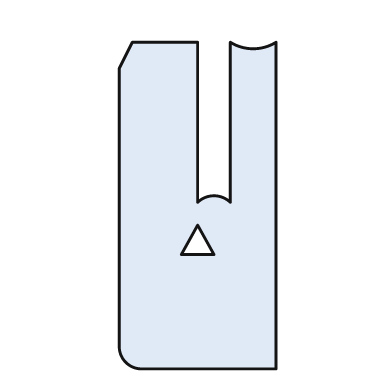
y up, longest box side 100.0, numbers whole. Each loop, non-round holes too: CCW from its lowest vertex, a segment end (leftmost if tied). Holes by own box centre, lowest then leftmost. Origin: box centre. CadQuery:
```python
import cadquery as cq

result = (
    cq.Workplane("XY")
    .moveTo(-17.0, -50.0)
    .lineTo(24.0, -50.0)
    .lineTo(24.0, 50.0)
    .threePointArc((17.0, 48.0), (10.0, 50.0))
    .lineTo(10.0, 1.0)
    .threePointArc((5.0, 3.0), (0.0, 1.0))
    .lineTo(0.0, 50.0)
    .lineTo(-20.0, 50.0)
    .lineTo(-24.0, 42.0)
    .lineTo(-24.0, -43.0)
    .threePointArc((-22.0, -48.0), (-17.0, -50.0))
    .close()
    .moveTo(-5.0, -15.0)
    .lineTo(5.0, -15.0)
    .lineTo(0.0, -6.0)
    .close()
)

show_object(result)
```